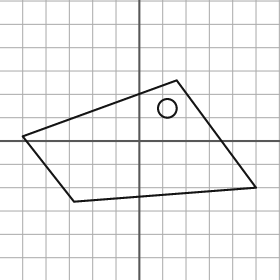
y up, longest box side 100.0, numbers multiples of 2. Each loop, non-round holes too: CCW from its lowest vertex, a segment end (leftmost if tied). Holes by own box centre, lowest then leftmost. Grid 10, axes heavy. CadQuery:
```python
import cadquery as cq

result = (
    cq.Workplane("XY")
    .moveTo(-28.0, -26.0)
    .lineTo(50.0, -20.0)
    .lineTo(16.0, 26.0)
    .lineTo(-50.0, 2.0)
    .close()
    .moveTo(12.0, 14.0)
    .circle(4.0)
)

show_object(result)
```